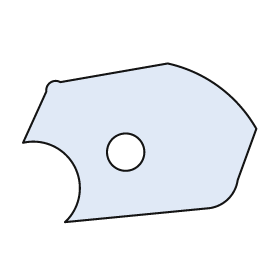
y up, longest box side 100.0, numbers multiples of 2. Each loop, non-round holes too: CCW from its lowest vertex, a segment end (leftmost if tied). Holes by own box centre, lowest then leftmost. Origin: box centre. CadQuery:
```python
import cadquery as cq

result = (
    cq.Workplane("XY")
    .moveTo(-32.0, -34.0)
    .lineTo(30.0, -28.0)
    .threePointArc((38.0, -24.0), (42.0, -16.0))
    .lineTo(50.0, 6.0)
    .threePointArc((34.0, 24.0), (12.0, 34.0))
    .lineTo(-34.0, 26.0)
    .threePointArc((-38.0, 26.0), (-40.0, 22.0))
    .lineTo(-50.0, 0.0)
    .threePointArc((-28.0, -10.0), (-32.0, -34.0))
    .close()
    .moveTo(-6.0, -4.0)
    .circle(8.0)
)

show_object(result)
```